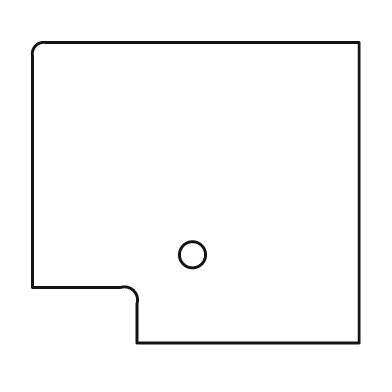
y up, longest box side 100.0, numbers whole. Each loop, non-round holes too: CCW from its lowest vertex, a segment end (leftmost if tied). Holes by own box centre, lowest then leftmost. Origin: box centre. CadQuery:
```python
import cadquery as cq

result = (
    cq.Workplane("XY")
    .moveTo(-18.0, -46.0)
    .lineTo(50.0, -46.0)
    .lineTo(50.0, 46.0)
    .lineTo(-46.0, 46.0)
    .threePointArc((-49.0, 45.0), (-50.0, 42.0))
    .lineTo(-50.0, -29.0)
    .lineTo(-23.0, -29.0)
    .threePointArc((-19.0, -30.0), (-18.0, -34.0))
    .close()
    .moveTo(-1.0, -19.0)
    .circle(4.0)
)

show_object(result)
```